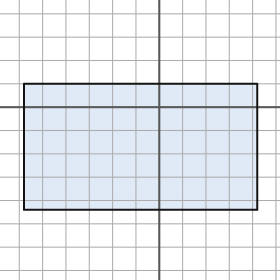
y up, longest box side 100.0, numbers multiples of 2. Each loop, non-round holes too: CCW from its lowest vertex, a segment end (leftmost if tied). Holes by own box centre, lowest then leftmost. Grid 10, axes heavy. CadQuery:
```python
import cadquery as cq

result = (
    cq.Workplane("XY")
    .moveTo(-58.0, -44.0)
    .lineTo(42.0, -44.0)
    .lineTo(42.0, 10.0)
    .lineTo(-58.0, 10.0)
    .close()
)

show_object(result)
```